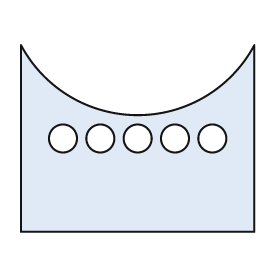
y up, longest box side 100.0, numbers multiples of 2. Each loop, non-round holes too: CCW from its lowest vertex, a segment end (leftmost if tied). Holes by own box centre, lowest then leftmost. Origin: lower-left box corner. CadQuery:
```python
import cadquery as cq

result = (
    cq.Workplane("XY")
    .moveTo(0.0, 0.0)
    .lineTo(100.0, 0.0)
    .lineTo(100.0, 80.0)
    .threePointArc((50.0, 50.0), (0.0, 80.0))
    .close()
    .moveTo(18.0, 40.0)
    .circle(6.0)
    .moveTo(34.0, 40.0)
    .circle(6.0)
    .moveTo(50.0, 40.0)
    .circle(6.0)
    .moveTo(66.0, 40.0)
    .circle(6.0)
    .moveTo(82.0, 40.0)
    .circle(6.0)
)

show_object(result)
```